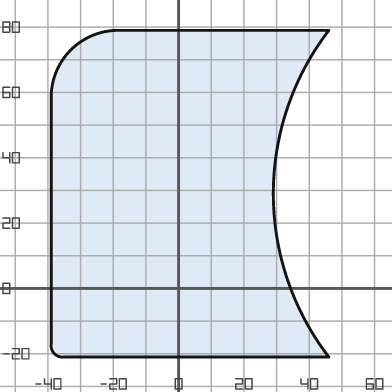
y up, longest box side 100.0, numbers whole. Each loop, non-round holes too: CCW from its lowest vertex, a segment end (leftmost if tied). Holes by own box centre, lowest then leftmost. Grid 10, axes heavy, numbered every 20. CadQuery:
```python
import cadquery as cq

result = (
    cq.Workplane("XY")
    .moveTo(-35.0, -21.0)
    .lineTo(46.0, -21.0)
    .threePointArc((29.0, 29.0), (46.0, 79.0))
    .lineTo(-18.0, 79.0)
    .threePointArc((-33.0, 73.0), (-39.0, 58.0))
    .lineTo(-39.0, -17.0)
    .threePointArc((-38.0, -20.0), (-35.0, -21.0))
    .close()
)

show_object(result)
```